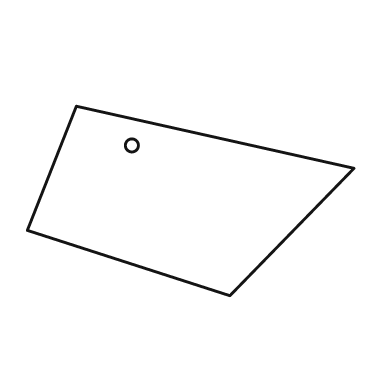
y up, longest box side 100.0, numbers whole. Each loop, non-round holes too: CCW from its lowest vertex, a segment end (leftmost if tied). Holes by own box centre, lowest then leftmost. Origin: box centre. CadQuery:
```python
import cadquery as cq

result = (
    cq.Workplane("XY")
    .moveTo(12.0, -29.0)
    .lineTo(50.0, 10.0)
    .lineTo(-35.0, 29.0)
    .lineTo(-50.0, -9.0)
    .close()
    .moveTo(-18.0, 17.0)
    .circle(2.0)
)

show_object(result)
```